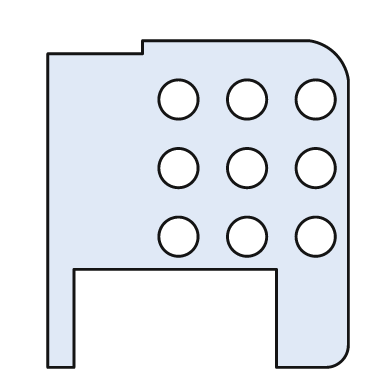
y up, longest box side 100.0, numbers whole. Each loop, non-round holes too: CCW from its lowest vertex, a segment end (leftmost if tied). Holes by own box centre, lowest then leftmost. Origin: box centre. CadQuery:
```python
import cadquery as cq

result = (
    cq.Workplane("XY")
    .moveTo(-46.0, -50.0)
    .lineTo(-38.0, -50.0)
    .lineTo(-38.0, -20.0)
    .lineTo(24.0, -20.0)
    .lineTo(24.0, -50.0)
    .lineTo(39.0, -50.0)
    .threePointArc((44.0, -48.0), (46.0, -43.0))
    .lineTo(46.0, 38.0)
    .threePointArc((42.0, 46.0), (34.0, 50.0))
    .lineTo(-17.0, 50.0)
    .lineTo(-17.0, 46.0)
    .lineTo(-46.0, 46.0)
    .close()
    .moveTo(-6.0, -10.0)
    .circle(6.0)
    .moveTo(15.0, -10.0)
    .circle(6.0)
    .moveTo(36.0, -10.0)
    .circle(6.0)
    .moveTo(-6.0, 11.0)
    .circle(6.0)
    .moveTo(15.0, 11.0)
    .circle(6.0)
    .moveTo(36.0, 11.0)
    .circle(6.0)
    .moveTo(-6.0, 32.0)
    .circle(6.0)
    .moveTo(15.0, 32.0)
    .circle(6.0)
    .moveTo(36.0, 32.0)
    .circle(6.0)
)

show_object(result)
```